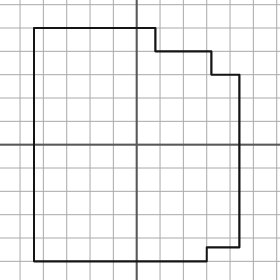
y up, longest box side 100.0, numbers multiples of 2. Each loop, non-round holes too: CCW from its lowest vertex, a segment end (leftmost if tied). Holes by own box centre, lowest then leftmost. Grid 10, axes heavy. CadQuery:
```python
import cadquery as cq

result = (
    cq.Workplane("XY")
    .moveTo(-44.0, -50.0)
    .lineTo(30.0, -50.0)
    .lineTo(30.0, -44.0)
    .lineTo(44.0, -44.0)
    .lineTo(44.0, 30.0)
    .lineTo(32.0, 30.0)
    .lineTo(32.0, 40.0)
    .lineTo(8.0, 40.0)
    .lineTo(8.0, 50.0)
    .lineTo(-44.0, 50.0)
    .close()
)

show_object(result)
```